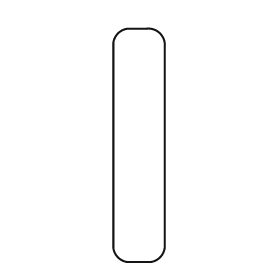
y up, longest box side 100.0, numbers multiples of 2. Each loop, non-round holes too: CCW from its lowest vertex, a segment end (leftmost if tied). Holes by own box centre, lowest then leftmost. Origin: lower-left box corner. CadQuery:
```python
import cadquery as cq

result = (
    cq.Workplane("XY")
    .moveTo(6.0, 0.0)
    .lineTo(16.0, 0.0)
    .threePointArc((20.0, 2.0), (22.0, 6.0))
    .lineTo(22.0, 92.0)
    .threePointArc((20.0, 98.0), (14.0, 100.0))
    .lineTo(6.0, 100.0)
    .threePointArc((2.0, 98.0), (0.0, 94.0))
    .lineTo(0.0, 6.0)
    .threePointArc((2.0, 2.0), (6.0, 0.0))
    .close()
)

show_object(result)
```